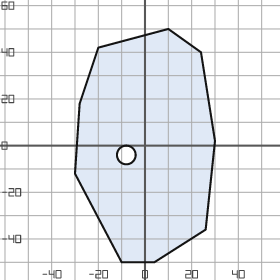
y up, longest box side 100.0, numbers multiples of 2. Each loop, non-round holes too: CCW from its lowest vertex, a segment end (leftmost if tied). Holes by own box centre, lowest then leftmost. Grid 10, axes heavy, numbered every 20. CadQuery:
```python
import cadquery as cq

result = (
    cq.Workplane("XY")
    .moveTo(-10.0, -50.0)
    .lineTo(4.0, -50.0)
    .lineTo(26.0, -36.0)
    .lineTo(30.0, 2.0)
    .lineTo(24.0, 40.0)
    .lineTo(10.0, 50.0)
    .lineTo(-20.0, 42.0)
    .lineTo(-28.0, 18.0)
    .lineTo(-30.0, -12.0)
    .close()
    .moveTo(-8.0, -4.0)
    .circle(4.0)
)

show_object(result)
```